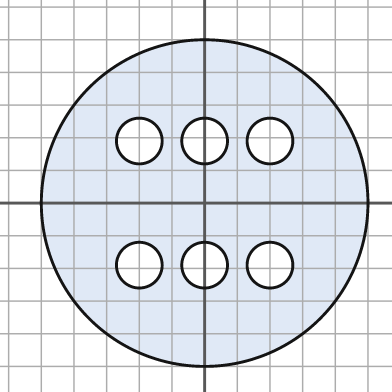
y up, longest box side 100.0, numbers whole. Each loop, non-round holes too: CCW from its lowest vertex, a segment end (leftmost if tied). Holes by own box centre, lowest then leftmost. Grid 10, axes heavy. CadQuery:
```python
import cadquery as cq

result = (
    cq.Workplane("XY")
    .moveTo(0.0, 0.0)
    .circle(50.0)
    .moveTo(-20.0, -19.0)
    .circle(7.0)
    .moveTo(0.0, -19.0)
    .circle(7.0)
    .moveTo(20.0, -19.0)
    .circle(7.0)
    .moveTo(-20.0, 19.0)
    .circle(7.0)
    .moveTo(0.0, 19.0)
    .circle(7.0)
    .moveTo(20.0, 19.0)
    .circle(7.0)
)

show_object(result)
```